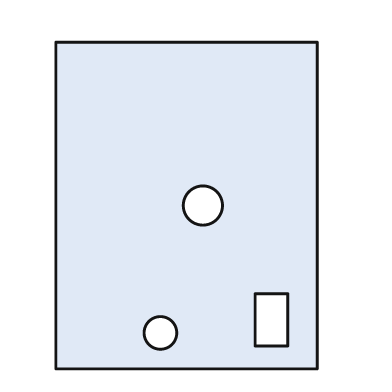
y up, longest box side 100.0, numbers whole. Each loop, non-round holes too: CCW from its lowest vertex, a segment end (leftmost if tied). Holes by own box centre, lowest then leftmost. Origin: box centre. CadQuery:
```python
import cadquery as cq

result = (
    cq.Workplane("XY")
    .moveTo(-40.0, -50.0)
    .lineTo(40.0, -50.0)
    .lineTo(40.0, 50.0)
    .lineTo(-40.0, 50.0)
    .close()
    .moveTo(-8.0, -39.0)
    .circle(5.0)
    .moveTo(21.0, -43.0)
    .lineTo(31.0, -43.0)
    .lineTo(31.0, -27.0)
    .lineTo(21.0, -27.0)
    .close()
    .moveTo(5.0, 0.0)
    .circle(6.0)
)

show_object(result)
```